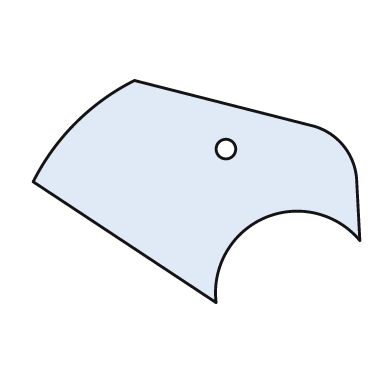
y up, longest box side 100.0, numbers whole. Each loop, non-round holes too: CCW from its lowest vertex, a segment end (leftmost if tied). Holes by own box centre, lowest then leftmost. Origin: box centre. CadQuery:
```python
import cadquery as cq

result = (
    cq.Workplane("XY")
    .moveTo(6.0, -34.0)
    .threePointArc((21.0, -8.0), (50.0, -15.0))
    .lineTo(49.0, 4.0)
    .threePointArc((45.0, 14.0), (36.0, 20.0))
    .lineTo(-19.0, 34.0)
    .threePointArc((-37.0, 21.0), (-50.0, 3.0))
    .close()
    .moveTo(9.0, 13.0)
    .circle(3.0)
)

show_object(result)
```